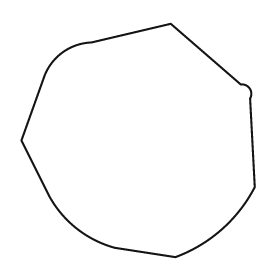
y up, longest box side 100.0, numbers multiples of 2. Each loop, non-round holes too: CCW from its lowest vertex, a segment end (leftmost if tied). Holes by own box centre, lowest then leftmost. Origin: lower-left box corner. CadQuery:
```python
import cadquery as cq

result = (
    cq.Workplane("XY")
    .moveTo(66.0, 0.0)
    .threePointArc((86.0, 12.0), (100.0, 30.0))
    .lineTo(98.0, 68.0)
    .threePointArc((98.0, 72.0), (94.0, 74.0))
    .lineTo(64.0, 100.0)
    .lineTo(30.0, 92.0)
    .threePointArc((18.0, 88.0), (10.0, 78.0))
    .lineTo(0.0, 50.0)
    .lineTo(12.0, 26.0)
    .threePointArc((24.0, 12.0), (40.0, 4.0))
    .close()
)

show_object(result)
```